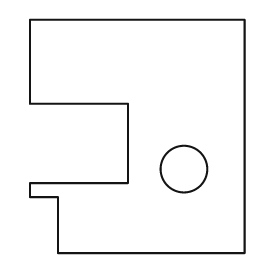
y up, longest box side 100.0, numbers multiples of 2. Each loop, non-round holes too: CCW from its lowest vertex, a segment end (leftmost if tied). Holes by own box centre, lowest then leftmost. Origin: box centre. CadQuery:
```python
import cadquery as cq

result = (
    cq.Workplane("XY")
    .moveTo(-34.0, -50.0)
    .lineTo(46.0, -50.0)
    .lineTo(46.0, 50.0)
    .lineTo(-46.0, 50.0)
    .lineTo(-46.0, 14.0)
    .lineTo(-4.0, 14.0)
    .lineTo(-4.0, -20.0)
    .lineTo(-46.0, -20.0)
    .lineTo(-46.0, -26.0)
    .lineTo(-34.0, -26.0)
    .close()
    .moveTo(20.0, -14.0)
    .circle(10.0)
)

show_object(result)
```